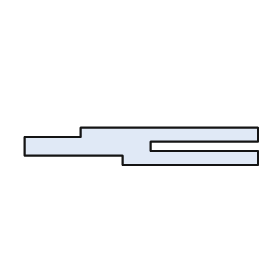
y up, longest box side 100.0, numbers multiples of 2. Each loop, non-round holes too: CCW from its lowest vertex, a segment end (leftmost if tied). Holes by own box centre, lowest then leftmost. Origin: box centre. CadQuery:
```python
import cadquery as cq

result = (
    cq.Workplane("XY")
    .moveTo(-8.0, -8.0)
    .lineTo(50.0, -8.0)
    .lineTo(50.0, -2.0)
    .lineTo(4.0, -2.0)
    .lineTo(4.0, 2.0)
    .lineTo(50.0, 2.0)
    .lineTo(50.0, 8.0)
    .lineTo(-26.0, 8.0)
    .lineTo(-26.0, 4.0)
    .lineTo(-50.0, 4.0)
    .lineTo(-50.0, -4.0)
    .lineTo(-8.0, -4.0)
    .close()
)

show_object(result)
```